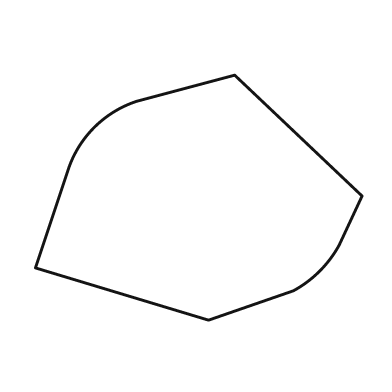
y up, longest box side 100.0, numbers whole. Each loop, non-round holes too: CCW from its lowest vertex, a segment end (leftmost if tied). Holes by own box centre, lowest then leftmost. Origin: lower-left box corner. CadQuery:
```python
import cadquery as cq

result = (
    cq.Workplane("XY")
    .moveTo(53.0, 0.0)
    .lineTo(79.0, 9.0)
    .threePointArc((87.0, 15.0), (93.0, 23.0))
    .lineTo(100.0, 38.0)
    .lineTo(61.0, 75.0)
    .lineTo(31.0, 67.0)
    .threePointArc((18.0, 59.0), (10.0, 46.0))
    .lineTo(0.0, 16.0)
    .close()
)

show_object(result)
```